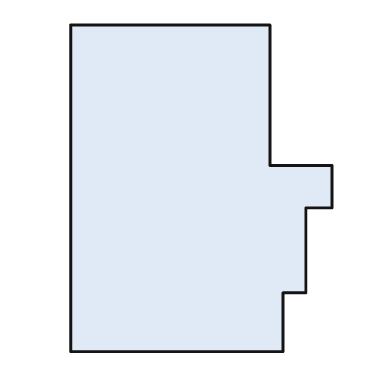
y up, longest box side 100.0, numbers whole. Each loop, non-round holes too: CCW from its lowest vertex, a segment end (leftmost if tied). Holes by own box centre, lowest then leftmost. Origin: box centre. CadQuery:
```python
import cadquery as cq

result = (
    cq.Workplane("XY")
    .moveTo(-40.0, -50.0)
    .lineTo(25.0, -50.0)
    .lineTo(25.0, -32.0)
    .lineTo(32.0, -32.0)
    .lineTo(32.0, -6.0)
    .lineTo(40.0, -6.0)
    .lineTo(40.0, 7.0)
    .lineTo(21.0, 7.0)
    .lineTo(21.0, 50.0)
    .lineTo(-40.0, 50.0)
    .close()
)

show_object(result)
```